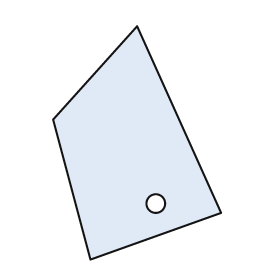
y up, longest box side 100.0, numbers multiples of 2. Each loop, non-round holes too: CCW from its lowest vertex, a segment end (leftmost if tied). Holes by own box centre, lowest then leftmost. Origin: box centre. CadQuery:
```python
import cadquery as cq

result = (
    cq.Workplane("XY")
    .moveTo(-20.0, -50.0)
    .lineTo(36.0, -30.0)
    .lineTo(0.0, 50.0)
    .lineTo(-36.0, 10.0)
    .close()
    .moveTo(8.0, -26.0)
    .circle(4.0)
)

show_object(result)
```